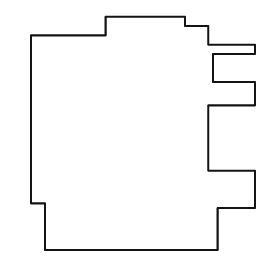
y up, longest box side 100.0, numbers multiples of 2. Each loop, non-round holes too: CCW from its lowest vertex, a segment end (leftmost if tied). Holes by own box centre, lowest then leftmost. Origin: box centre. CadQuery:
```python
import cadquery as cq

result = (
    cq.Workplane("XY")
    .moveTo(-42.0, -50.0)
    .lineTo(32.0, -50.0)
    .lineTo(32.0, -32.0)
    .lineTo(48.0, -32.0)
    .lineTo(48.0, -16.0)
    .lineTo(28.0, -16.0)
    .lineTo(28.0, 12.0)
    .lineTo(48.0, 12.0)
    .lineTo(48.0, 22.0)
    .lineTo(30.0, 22.0)
    .lineTo(30.0, 34.0)
    .lineTo(48.0, 34.0)
    .lineTo(48.0, 38.0)
    .lineTo(28.0, 38.0)
    .lineTo(28.0, 46.0)
    .lineTo(18.0, 46.0)
    .lineTo(18.0, 50.0)
    .lineTo(-16.0, 50.0)
    .lineTo(-16.0, 42.0)
    .lineTo(-48.0, 42.0)
    .lineTo(-48.0, -30.0)
    .lineTo(-42.0, -30.0)
    .close()
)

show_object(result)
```